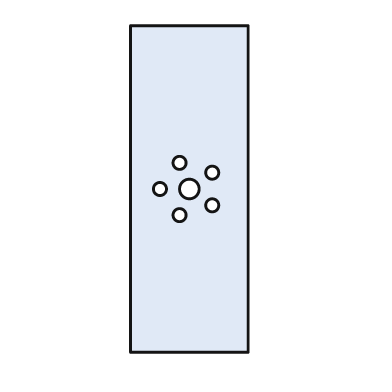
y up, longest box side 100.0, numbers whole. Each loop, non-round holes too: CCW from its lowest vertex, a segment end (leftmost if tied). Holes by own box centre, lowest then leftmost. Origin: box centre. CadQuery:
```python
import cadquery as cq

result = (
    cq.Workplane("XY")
    .moveTo(-18.0, -50.0)
    .lineTo(18.0, -50.0)
    .lineTo(18.0, 50.0)
    .lineTo(-18.0, 50.0)
    .close()
    .moveTo(-3.0, -8.0)
    .circle(2.0)
    .moveTo(7.0, -5.0)
    .circle(2.0)
    .moveTo(-9.0, 0.0)
    .circle(2.0)
    .moveTo(0.0, 0.0)
    .circle(3.0)
    .moveTo(7.0, 5.0)
    .circle(2.0)
    .moveTo(-3.0, 8.0)
    .circle(2.0)
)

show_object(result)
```